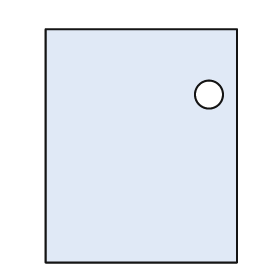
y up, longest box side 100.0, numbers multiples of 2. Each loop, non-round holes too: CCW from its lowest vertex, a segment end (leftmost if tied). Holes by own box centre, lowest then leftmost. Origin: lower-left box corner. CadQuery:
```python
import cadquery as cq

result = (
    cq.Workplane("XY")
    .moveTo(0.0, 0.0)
    .lineTo(82.0, 0.0)
    .lineTo(82.0, 100.0)
    .lineTo(0.0, 100.0)
    .close()
    .moveTo(70.0, 72.0)
    .circle(6.0)
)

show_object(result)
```